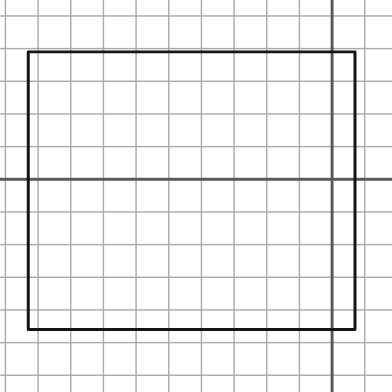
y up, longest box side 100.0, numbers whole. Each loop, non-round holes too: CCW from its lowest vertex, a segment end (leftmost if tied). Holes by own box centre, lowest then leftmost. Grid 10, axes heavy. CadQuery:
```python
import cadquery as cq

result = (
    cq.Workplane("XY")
    .moveTo(-93.0, -46.0)
    .lineTo(7.0, -46.0)
    .lineTo(7.0, 39.0)
    .lineTo(-93.0, 39.0)
    .close()
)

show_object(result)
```